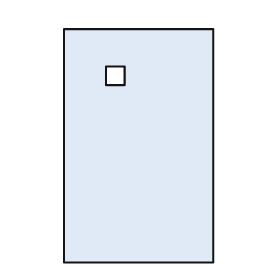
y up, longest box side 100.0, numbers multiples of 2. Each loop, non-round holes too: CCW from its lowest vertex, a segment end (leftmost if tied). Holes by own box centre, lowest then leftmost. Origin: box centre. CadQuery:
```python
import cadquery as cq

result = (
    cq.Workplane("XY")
    .moveTo(-32.0, -50.0)
    .lineTo(32.0, -50.0)
    .lineTo(32.0, 50.0)
    .lineTo(-32.0, 50.0)
    .close()
    .moveTo(-14.0, 26.0)
    .lineTo(-6.0, 26.0)
    .lineTo(-6.0, 34.0)
    .lineTo(-14.0, 34.0)
    .close()
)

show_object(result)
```